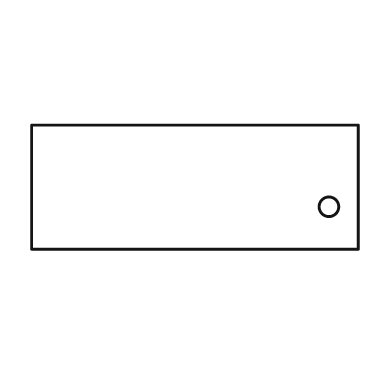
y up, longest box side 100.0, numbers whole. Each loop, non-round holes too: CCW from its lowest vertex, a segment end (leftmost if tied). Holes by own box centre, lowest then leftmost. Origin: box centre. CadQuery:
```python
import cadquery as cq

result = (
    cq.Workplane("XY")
    .moveTo(-50.0, -19.0)
    .lineTo(50.0, -19.0)
    .lineTo(50.0, 19.0)
    .lineTo(-50.0, 19.0)
    .close()
    .moveTo(41.0, -6.0)
    .circle(3.0)
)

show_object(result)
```